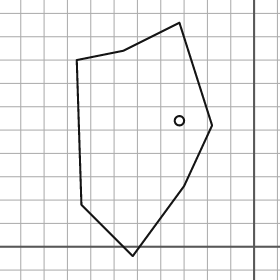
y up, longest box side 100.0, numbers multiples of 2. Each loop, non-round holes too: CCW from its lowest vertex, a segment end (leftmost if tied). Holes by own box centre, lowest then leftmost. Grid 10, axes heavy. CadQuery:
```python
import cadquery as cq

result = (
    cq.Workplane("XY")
    .moveTo(-52.0, -4.0)
    .lineTo(-30.0, 26.0)
    .lineTo(-18.0, 52.0)
    .lineTo(-32.0, 96.0)
    .lineTo(-56.0, 84.0)
    .lineTo(-76.0, 80.0)
    .lineTo(-74.0, 18.0)
    .close()
    .moveTo(-32.0, 54.0)
    .circle(2.0)
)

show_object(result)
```